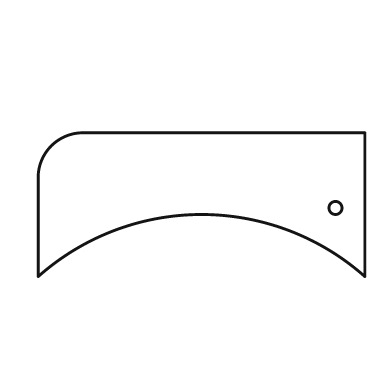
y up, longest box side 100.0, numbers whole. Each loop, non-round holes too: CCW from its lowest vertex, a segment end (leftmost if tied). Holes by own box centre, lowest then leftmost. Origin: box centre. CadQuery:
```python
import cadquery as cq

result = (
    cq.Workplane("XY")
    .moveTo(-50.0, -22.0)
    .threePointArc((0.0, -3.0), (50.0, -22.0))
    .lineTo(50.0, 22.0)
    .lineTo(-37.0, 22.0)
    .threePointArc((-46.0, 18.0), (-50.0, 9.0))
    .close()
    .moveTo(41.0, -1.0)
    .circle(2.0)
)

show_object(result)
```